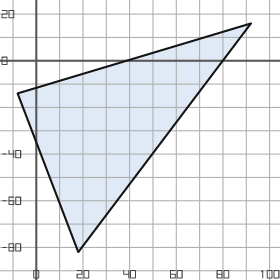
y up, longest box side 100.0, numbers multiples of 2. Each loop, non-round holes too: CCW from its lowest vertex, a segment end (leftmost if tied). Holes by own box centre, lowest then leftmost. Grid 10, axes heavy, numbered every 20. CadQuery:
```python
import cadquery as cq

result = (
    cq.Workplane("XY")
    .moveTo(18.0, -82.0)
    .lineTo(92.0, 16.0)
    .lineTo(-8.0, -14.0)
    .close()
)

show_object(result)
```